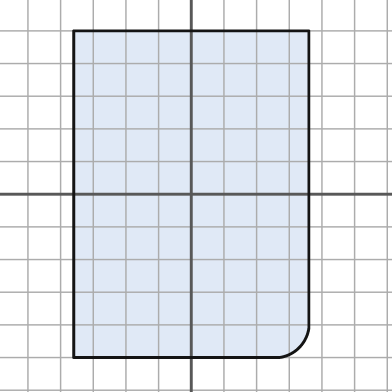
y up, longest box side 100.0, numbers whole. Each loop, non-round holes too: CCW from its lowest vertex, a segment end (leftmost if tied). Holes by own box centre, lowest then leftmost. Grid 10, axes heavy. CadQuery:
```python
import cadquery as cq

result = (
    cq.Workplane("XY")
    .moveTo(-36.0, -50.0)
    .lineTo(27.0, -50.0)
    .threePointArc((33.0, -47.0), (36.0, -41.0))
    .lineTo(36.0, 50.0)
    .lineTo(-36.0, 50.0)
    .close()
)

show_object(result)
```